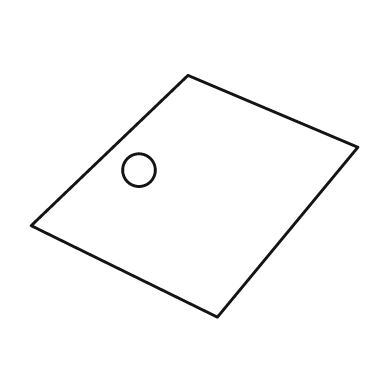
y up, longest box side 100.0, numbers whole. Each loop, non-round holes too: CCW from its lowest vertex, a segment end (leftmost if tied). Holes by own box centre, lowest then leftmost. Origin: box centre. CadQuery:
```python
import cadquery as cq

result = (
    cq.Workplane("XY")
    .moveTo(7.0, -37.0)
    .lineTo(50.0, 15.0)
    .lineTo(-2.0, 37.0)
    .lineTo(-50.0, -9.0)
    .close()
    .moveTo(-17.0, 8.0)
    .circle(5.0)
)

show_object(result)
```